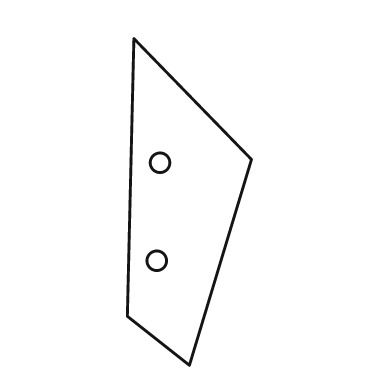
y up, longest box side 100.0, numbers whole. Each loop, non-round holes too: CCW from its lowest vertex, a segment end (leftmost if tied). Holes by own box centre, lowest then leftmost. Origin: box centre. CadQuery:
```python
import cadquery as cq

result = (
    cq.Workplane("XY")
    .moveTo(0.0, -50.0)
    .lineTo(19.0, 13.0)
    .lineTo(-17.0, 50.0)
    .lineTo(-19.0, -35.0)
    .close()
    .moveTo(-10.0, -18.0)
    .circle(3.0)
    .moveTo(-9.0, 12.0)
    .circle(3.0)
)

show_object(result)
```